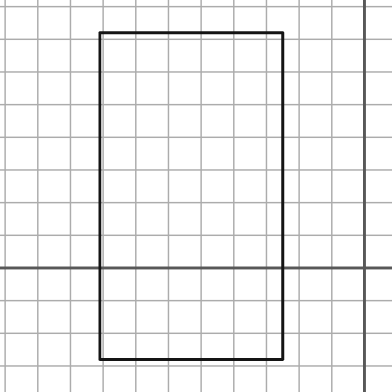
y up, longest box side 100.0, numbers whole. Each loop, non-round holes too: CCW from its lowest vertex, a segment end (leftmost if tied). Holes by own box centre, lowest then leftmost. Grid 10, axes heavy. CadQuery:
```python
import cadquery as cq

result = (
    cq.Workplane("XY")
    .moveTo(-81.0, -28.0)
    .lineTo(-25.0, -28.0)
    .lineTo(-25.0, 72.0)
    .lineTo(-81.0, 72.0)
    .close()
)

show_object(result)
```